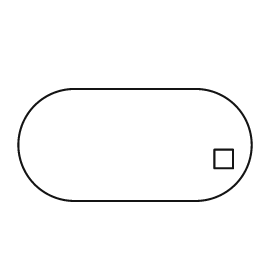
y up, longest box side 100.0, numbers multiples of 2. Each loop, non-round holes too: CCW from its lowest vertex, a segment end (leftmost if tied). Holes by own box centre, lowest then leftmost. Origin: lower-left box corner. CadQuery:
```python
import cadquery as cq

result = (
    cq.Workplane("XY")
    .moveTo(24.0, 0.0)
    .lineTo(76.0, 0.0)
    .threePointArc((100.0, 24.0), (76.0, 48.0))
    .lineTo(24.0, 48.0)
    .threePointArc((0.0, 24.0), (24.0, 0.0))
    .close()
    .moveTo(84.0, 14.0)
    .lineTo(92.0, 14.0)
    .lineTo(92.0, 22.0)
    .lineTo(84.0, 22.0)
    .close()
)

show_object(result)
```